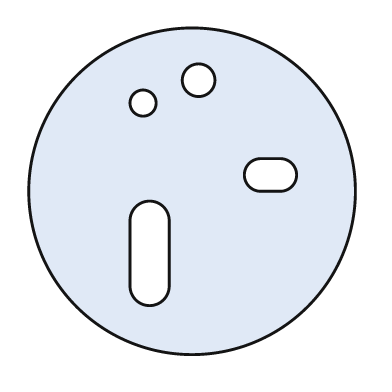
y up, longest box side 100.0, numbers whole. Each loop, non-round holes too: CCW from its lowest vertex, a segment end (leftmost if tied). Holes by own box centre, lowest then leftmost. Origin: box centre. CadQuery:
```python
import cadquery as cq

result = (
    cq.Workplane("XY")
    .moveTo(0.0, 0.0)
    .circle(50.0)
    .moveTo(-19.0, -29.0)
    .threePointArc((-13.0, -35.0), (-7.0, -29.0))
    .lineTo(-7.0, -9.0)
    .threePointArc((-13.0, -3.0), (-19.0, -9.0))
    .close()
    .moveTo(21.0, 0.0)
    .lineTo(27.0, 0.0)
    .threePointArc((32.0, 5.0), (27.0, 10.0))
    .lineTo(21.0, 10.0)
    .threePointArc((16.0, 5.0), (21.0, 0.0))
    .close()
    .moveTo(-15.0, 27.0)
    .circle(4.0)
    .moveTo(2.0, 34.0)
    .circle(5.0)
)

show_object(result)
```